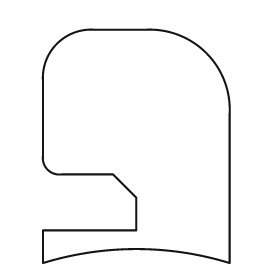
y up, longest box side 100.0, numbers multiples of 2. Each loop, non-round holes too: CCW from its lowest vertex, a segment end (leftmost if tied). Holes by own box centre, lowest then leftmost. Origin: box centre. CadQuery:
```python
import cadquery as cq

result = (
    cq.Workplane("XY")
    .moveTo(-40.0, -50.0)
    .threePointArc((0.0, -44.0), (40.0, -50.0))
    .lineTo(40.0, 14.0)
    .threePointArc((30.0, 40.0), (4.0, 50.0))
    .lineTo(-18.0, 50.0)
    .threePointArc((-34.0, 44.0), (-40.0, 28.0))
    .lineTo(-40.0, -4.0)
    .threePointArc((-38.0, -10.0), (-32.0, -12.0))
    .lineTo(-10.0, -12.0)
    .lineTo(0.0, -22.0)
    .lineTo(0.0, -36.0)
    .lineTo(-40.0, -36.0)
    .close()
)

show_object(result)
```